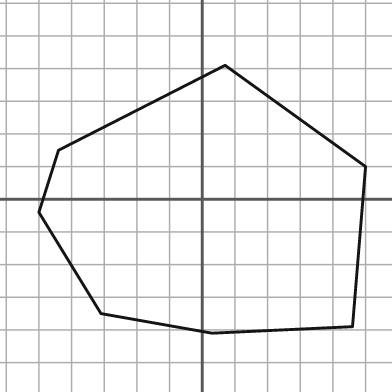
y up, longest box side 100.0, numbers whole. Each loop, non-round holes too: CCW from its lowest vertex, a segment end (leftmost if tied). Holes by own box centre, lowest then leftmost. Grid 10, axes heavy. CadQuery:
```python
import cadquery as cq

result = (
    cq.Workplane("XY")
    .moveTo(3.0, -41.0)
    .lineTo(46.0, -39.0)
    .lineTo(50.0, 10.0)
    .lineTo(7.0, 41.0)
    .lineTo(-44.0, 15.0)
    .lineTo(-50.0, -4.0)
    .lineTo(-31.0, -35.0)
    .close()
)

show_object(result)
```